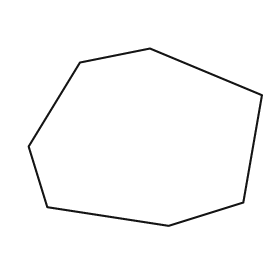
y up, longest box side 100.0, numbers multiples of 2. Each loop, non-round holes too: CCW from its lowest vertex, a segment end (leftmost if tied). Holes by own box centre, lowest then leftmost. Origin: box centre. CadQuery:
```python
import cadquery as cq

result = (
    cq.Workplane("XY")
    .moveTo(10.0, -38.0)
    .lineTo(42.0, -28.0)
    .lineTo(50.0, 18.0)
    .lineTo(2.0, 38.0)
    .lineTo(-28.0, 32.0)
    .lineTo(-50.0, -4.0)
    .lineTo(-42.0, -30.0)
    .close()
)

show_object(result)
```